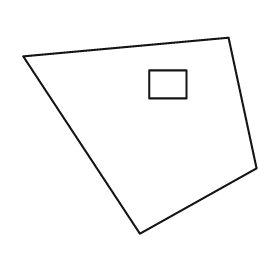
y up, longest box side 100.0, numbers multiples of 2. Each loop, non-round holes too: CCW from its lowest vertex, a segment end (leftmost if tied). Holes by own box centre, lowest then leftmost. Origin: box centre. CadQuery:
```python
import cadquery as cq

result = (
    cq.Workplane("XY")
    .moveTo(0.0, -42.0)
    .lineTo(50.0, -14.0)
    .lineTo(38.0, 42.0)
    .lineTo(-50.0, 34.0)
    .close()
    .moveTo(4.0, 16.0)
    .lineTo(20.0, 16.0)
    .lineTo(20.0, 28.0)
    .lineTo(4.0, 28.0)
    .close()
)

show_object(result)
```